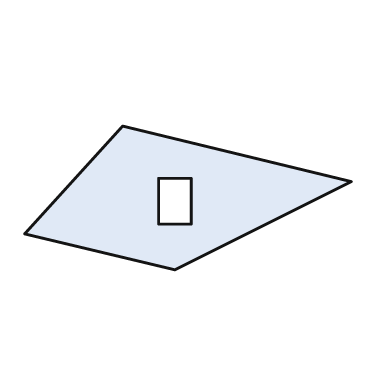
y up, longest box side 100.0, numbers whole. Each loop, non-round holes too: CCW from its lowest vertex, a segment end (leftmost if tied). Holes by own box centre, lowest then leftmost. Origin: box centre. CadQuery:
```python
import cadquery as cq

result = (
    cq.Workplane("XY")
    .moveTo(-4.0, -22.0)
    .lineTo(50.0, 5.0)
    .lineTo(-20.0, 22.0)
    .lineTo(-50.0, -11.0)
    .close()
    .moveTo(-9.0, -8.0)
    .lineTo(1.0, -8.0)
    .lineTo(1.0, 6.0)
    .lineTo(-9.0, 6.0)
    .close()
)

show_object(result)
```